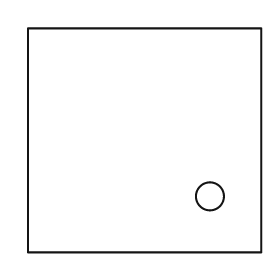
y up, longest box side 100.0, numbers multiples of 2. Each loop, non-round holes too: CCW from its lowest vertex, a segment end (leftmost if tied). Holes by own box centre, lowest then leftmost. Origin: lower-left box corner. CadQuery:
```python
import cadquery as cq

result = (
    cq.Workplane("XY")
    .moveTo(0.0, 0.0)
    .lineTo(100.0, 0.0)
    .lineTo(100.0, 96.0)
    .lineTo(0.0, 96.0)
    .close()
    .moveTo(78.0, 24.0)
    .circle(6.0)
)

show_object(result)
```